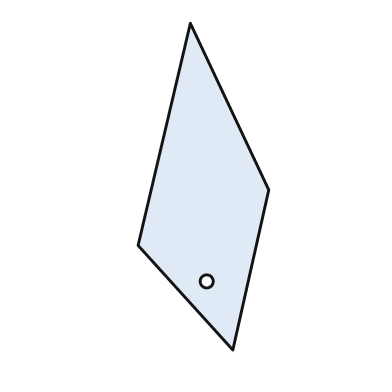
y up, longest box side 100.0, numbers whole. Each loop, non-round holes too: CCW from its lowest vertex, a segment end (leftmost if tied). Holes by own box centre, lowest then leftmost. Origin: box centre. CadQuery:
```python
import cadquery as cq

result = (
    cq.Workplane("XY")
    .moveTo(9.0, -50.0)
    .lineTo(20.0, -1.0)
    .lineTo(-4.0, 50.0)
    .lineTo(-20.0, -18.0)
    .close()
    .moveTo(1.0, -29.0)
    .circle(2.0)
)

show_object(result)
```